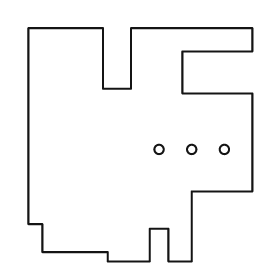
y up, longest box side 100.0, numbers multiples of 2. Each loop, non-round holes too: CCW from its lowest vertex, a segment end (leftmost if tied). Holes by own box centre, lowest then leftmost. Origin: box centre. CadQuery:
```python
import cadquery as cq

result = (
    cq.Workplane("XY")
    .moveTo(-14.0, -50.0)
    .lineTo(4.0, -50.0)
    .lineTo(4.0, -36.0)
    .lineTo(12.0, -36.0)
    .lineTo(12.0, -50.0)
    .lineTo(22.0, -50.0)
    .lineTo(22.0, -20.0)
    .lineTo(48.0, -20.0)
    .lineTo(48.0, 22.0)
    .lineTo(18.0, 22.0)
    .lineTo(18.0, 40.0)
    .lineTo(48.0, 40.0)
    .lineTo(48.0, 50.0)
    .lineTo(-4.0, 50.0)
    .lineTo(-4.0, 24.0)
    .lineTo(-16.0, 24.0)
    .lineTo(-16.0, 50.0)
    .lineTo(-48.0, 50.0)
    .lineTo(-48.0, -34.0)
    .lineTo(-42.0, -34.0)
    .lineTo(-42.0, -46.0)
    .lineTo(-14.0, -46.0)
    .close()
    .moveTo(8.0, -2.0)
    .circle(2.0)
    .moveTo(22.0, -2.0)
    .circle(2.0)
    .moveTo(36.0, -2.0)
    .circle(2.0)
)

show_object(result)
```